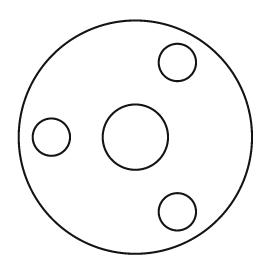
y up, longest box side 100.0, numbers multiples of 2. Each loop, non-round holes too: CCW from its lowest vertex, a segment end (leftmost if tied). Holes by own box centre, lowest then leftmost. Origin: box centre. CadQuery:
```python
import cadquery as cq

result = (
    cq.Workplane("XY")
    .moveTo(0.0, 0.0)
    .circle(50.0)
    .moveTo(18.0, -32.0)
    .circle(8.0)
    .moveTo(-36.0, 0.0)
    .circle(8.0)
    .moveTo(0.0, 0.0)
    .circle(14.0)
    .moveTo(18.0, 32.0)
    .circle(8.0)
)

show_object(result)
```